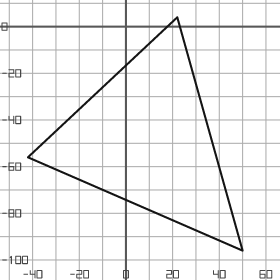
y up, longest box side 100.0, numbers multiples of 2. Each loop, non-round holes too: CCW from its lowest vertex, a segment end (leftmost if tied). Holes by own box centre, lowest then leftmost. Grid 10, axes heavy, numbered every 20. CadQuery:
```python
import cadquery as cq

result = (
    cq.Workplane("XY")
    .moveTo(50.0, -96.0)
    .lineTo(22.0, 4.0)
    .lineTo(-42.0, -56.0)
    .close()
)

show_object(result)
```